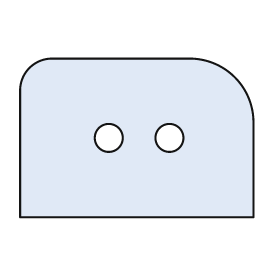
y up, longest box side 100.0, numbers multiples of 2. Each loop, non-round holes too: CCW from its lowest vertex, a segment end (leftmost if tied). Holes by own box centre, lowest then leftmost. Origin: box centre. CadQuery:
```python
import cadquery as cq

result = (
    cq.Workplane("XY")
    .moveTo(-50.0, -34.0)
    .lineTo(50.0, -34.0)
    .lineTo(50.0, 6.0)
    .threePointArc((42.0, 26.0), (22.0, 34.0))
    .lineTo(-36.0, 34.0)
    .threePointArc((-46.0, 30.0), (-50.0, 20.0))
    .close()
    .moveTo(-12.0, 0.0)
    .circle(6.0)
    .moveTo(14.0, 0.0)
    .circle(6.0)
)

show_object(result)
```